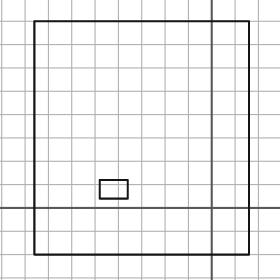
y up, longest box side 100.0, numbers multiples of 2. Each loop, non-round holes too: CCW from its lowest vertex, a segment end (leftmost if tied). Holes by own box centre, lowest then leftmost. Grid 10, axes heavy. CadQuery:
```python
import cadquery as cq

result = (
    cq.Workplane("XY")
    .moveTo(-76.0, -20.0)
    .lineTo(16.0, -20.0)
    .lineTo(16.0, 80.0)
    .lineTo(-76.0, 80.0)
    .close()
    .moveTo(-48.0, 4.0)
    .lineTo(-36.0, 4.0)
    .lineTo(-36.0, 12.0)
    .lineTo(-48.0, 12.0)
    .close()
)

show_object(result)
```